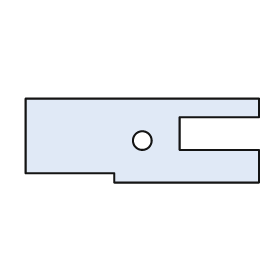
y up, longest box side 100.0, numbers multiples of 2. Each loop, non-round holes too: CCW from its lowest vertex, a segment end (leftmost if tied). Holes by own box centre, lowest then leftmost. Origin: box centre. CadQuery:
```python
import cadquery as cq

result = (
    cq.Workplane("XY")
    .moveTo(-12.0, -18.0)
    .lineTo(50.0, -18.0)
    .lineTo(50.0, -4.0)
    .lineTo(16.0, -4.0)
    .lineTo(16.0, 10.0)
    .lineTo(50.0, 10.0)
    .lineTo(50.0, 18.0)
    .lineTo(-50.0, 18.0)
    .lineTo(-50.0, -14.0)
    .lineTo(-12.0, -14.0)
    .close()
    .moveTo(0.0, 0.0)
    .circle(4.0)
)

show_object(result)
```